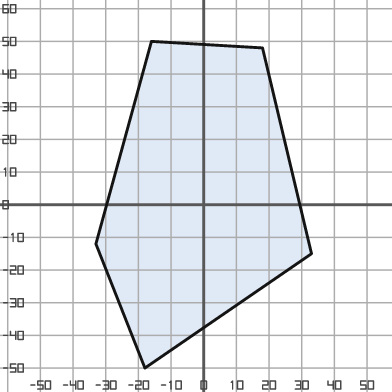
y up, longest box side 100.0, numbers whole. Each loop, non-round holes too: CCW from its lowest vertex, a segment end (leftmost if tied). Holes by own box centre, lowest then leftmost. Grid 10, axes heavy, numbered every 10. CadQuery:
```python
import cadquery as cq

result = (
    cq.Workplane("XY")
    .moveTo(-18.0, -50.0)
    .lineTo(33.0, -15.0)
    .lineTo(18.0, 48.0)
    .lineTo(-16.0, 50.0)
    .lineTo(-33.0, -12.0)
    .close()
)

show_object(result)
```